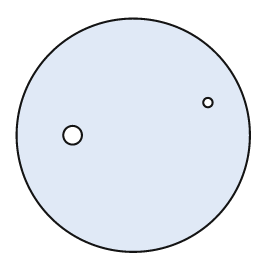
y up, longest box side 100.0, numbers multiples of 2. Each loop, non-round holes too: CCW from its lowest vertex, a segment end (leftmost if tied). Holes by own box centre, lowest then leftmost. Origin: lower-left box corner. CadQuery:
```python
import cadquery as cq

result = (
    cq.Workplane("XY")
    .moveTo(50.0, 50.0)
    .circle(50.0)
    .moveTo(24.0, 50.0)
    .circle(4.0)
    .moveTo(82.0, 64.0)
    .circle(2.0)
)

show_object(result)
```